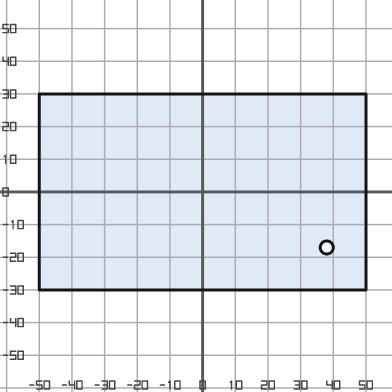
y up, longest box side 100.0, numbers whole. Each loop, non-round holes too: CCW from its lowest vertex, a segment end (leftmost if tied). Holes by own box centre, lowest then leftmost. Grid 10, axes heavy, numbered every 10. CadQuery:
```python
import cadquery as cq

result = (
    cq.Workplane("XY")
    .moveTo(-50.0, -30.0)
    .lineTo(50.0, -30.0)
    .lineTo(50.0, 30.0)
    .lineTo(-50.0, 30.0)
    .close()
    .moveTo(38.0, -17.0)
    .circle(2.0)
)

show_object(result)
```